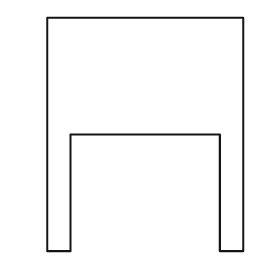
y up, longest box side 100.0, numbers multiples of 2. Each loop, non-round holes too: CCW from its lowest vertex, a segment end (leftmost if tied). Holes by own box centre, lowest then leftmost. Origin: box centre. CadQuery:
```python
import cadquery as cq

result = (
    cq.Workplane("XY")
    .moveTo(-42.0, -50.0)
    .lineTo(-32.0, -50.0)
    .lineTo(-32.0, 0.0)
    .lineTo(32.0, 0.0)
    .lineTo(32.0, -50.0)
    .lineTo(42.0, -50.0)
    .lineTo(42.0, 50.0)
    .lineTo(-42.0, 50.0)
    .close()
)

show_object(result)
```